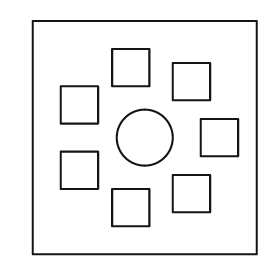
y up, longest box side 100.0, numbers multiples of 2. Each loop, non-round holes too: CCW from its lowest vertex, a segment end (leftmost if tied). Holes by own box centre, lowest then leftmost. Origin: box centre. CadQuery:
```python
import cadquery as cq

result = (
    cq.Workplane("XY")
    .moveTo(-48.0, -50.0)
    .lineTo(48.0, -50.0)
    .lineTo(48.0, 50.0)
    .lineTo(-48.0, 50.0)
    .close()
    .moveTo(-14.0, -38.0)
    .lineTo(2.0, -38.0)
    .lineTo(2.0, -22.0)
    .lineTo(-14.0, -22.0)
    .close()
    .moveTo(12.0, -32.0)
    .lineTo(28.0, -32.0)
    .lineTo(28.0, -16.0)
    .lineTo(12.0, -16.0)
    .close()
    .moveTo(-36.0, -22.0)
    .lineTo(-20.0, -22.0)
    .lineTo(-20.0, -6.0)
    .lineTo(-36.0, -6.0)
    .close()
    .moveTo(0.0, 0.0)
    .circle(12.0)
    .moveTo(24.0, -8.0)
    .lineTo(40.0, -8.0)
    .lineTo(40.0, 8.0)
    .lineTo(24.0, 8.0)
    .close()
    .moveTo(-36.0, 6.0)
    .lineTo(-20.0, 6.0)
    .lineTo(-20.0, 22.0)
    .lineTo(-36.0, 22.0)
    .close()
    .moveTo(12.0, 16.0)
    .lineTo(28.0, 16.0)
    .lineTo(28.0, 32.0)
    .lineTo(12.0, 32.0)
    .close()
    .moveTo(-14.0, 22.0)
    .lineTo(2.0, 22.0)
    .lineTo(2.0, 38.0)
    .lineTo(-14.0, 38.0)
    .close()
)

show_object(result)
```